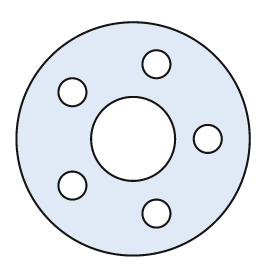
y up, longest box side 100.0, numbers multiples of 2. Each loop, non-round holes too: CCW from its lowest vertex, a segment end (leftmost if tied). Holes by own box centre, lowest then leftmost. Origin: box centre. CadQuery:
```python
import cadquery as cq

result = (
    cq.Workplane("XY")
    .moveTo(0.0, 0.0)
    .circle(50.0)
    .moveTo(10.0, -32.0)
    .circle(6.0)
    .moveTo(-26.0, -20.0)
    .circle(6.0)
    .moveTo(0.0, 0.0)
    .circle(18.0)
    .moveTo(32.0, 0.0)
    .circle(6.0)
    .moveTo(-26.0, 20.0)
    .circle(6.0)
    .moveTo(10.0, 32.0)
    .circle(6.0)
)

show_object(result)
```